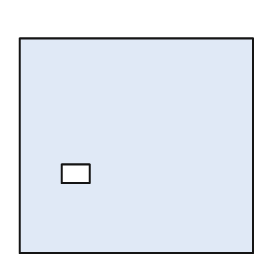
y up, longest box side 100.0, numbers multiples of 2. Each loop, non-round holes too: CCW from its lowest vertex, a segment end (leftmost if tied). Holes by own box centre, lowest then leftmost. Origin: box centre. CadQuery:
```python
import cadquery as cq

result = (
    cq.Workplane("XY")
    .moveTo(-50.0, -46.0)
    .lineTo(50.0, -46.0)
    .lineTo(50.0, 46.0)
    .lineTo(-50.0, 46.0)
    .close()
    .moveTo(-32.0, -16.0)
    .lineTo(-20.0, -16.0)
    .lineTo(-20.0, -8.0)
    .lineTo(-32.0, -8.0)
    .close()
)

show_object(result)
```